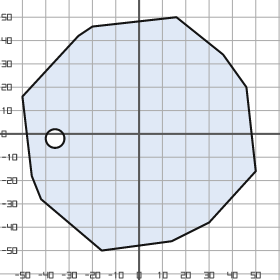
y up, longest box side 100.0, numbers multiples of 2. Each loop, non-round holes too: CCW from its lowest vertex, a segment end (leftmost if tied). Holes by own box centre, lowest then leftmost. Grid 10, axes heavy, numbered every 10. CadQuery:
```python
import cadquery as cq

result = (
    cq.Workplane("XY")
    .moveTo(-16.0, -50.0)
    .lineTo(14.0, -46.0)
    .lineTo(30.0, -38.0)
    .lineTo(50.0, -16.0)
    .lineTo(46.0, 20.0)
    .lineTo(36.0, 34.0)
    .lineTo(16.0, 50.0)
    .lineTo(-20.0, 46.0)
    .lineTo(-26.0, 42.0)
    .lineTo(-50.0, 16.0)
    .lineTo(-46.0, -18.0)
    .lineTo(-42.0, -28.0)
    .close()
    .moveTo(-36.0, -2.0)
    .circle(4.0)
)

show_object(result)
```